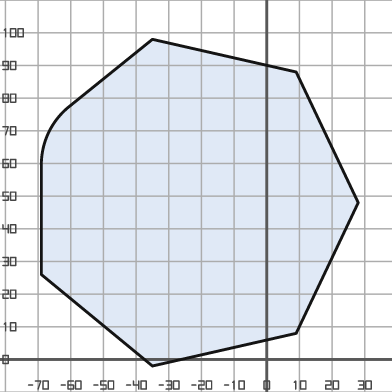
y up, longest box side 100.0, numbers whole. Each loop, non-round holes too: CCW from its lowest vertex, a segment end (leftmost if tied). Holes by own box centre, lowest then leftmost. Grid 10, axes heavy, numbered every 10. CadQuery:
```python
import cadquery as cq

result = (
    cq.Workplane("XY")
    .moveTo(-35.0, -2.0)
    .lineTo(9.0, 8.0)
    .lineTo(28.0, 48.0)
    .lineTo(9.0, 88.0)
    .lineTo(-35.0, 98.0)
    .lineTo(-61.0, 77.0)
    .threePointArc((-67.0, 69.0), (-69.0, 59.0))
    .lineTo(-69.0, 26.0)
    .close()
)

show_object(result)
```